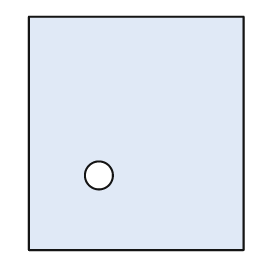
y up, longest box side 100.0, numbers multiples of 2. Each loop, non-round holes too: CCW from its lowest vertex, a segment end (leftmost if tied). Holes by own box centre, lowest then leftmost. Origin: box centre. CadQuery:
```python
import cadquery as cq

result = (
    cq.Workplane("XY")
    .moveTo(-46.0, -50.0)
    .lineTo(46.0, -50.0)
    .lineTo(46.0, 50.0)
    .lineTo(-46.0, 50.0)
    .close()
    .moveTo(-16.0, -18.0)
    .circle(6.0)
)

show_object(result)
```